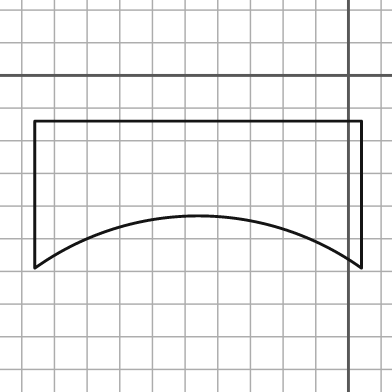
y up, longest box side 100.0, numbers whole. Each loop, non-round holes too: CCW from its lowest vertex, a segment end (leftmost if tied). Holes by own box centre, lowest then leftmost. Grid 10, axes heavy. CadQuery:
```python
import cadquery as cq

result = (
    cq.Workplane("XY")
    .moveTo(-96.0, -59.0)
    .threePointArc((-46.0, -43.0), (4.0, -59.0))
    .lineTo(4.0, -14.0)
    .lineTo(-96.0, -14.0)
    .close()
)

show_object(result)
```